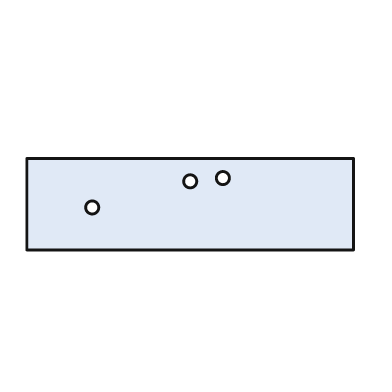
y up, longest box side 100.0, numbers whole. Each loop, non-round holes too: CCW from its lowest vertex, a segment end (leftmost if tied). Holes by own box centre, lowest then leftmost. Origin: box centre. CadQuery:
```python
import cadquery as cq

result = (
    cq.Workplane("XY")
    .moveTo(-50.0, -14.0)
    .lineTo(50.0, -14.0)
    .lineTo(50.0, 14.0)
    .lineTo(-50.0, 14.0)
    .close()
    .moveTo(-30.0, -1.0)
    .circle(2.0)
    .moveTo(0.0, 7.0)
    .circle(2.0)
    .moveTo(10.0, 8.0)
    .circle(2.0)
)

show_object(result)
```